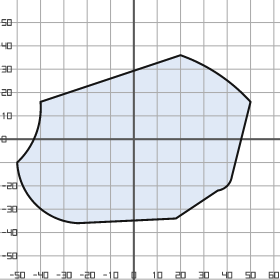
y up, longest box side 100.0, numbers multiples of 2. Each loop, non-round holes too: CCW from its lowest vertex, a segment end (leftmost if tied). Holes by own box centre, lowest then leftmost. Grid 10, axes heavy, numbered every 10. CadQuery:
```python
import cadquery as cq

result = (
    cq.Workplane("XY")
    .moveTo(-24.0, -36.0)
    .lineTo(18.0, -34.0)
    .lineTo(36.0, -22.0)
    .threePointArc((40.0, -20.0), (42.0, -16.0))
    .lineTo(50.0, 16.0)
    .threePointArc((36.0, 28.0), (20.0, 36.0))
    .lineTo(-40.0, 16.0)
    .threePointArc((-42.0, 2.0), (-50.0, -10.0))
    .threePointArc((-42.0, -28.0), (-24.0, -36.0))
    .close()
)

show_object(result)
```